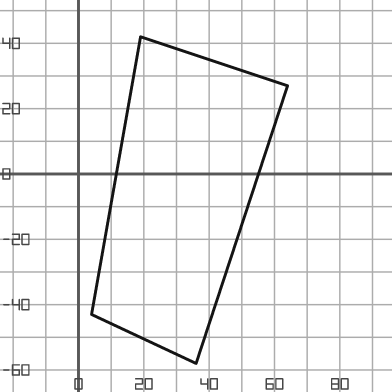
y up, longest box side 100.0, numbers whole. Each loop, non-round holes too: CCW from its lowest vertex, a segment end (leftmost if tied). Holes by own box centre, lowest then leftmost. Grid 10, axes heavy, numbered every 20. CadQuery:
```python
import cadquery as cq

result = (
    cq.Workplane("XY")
    .moveTo(36.0, -58.0)
    .lineTo(64.0, 27.0)
    .lineTo(19.0, 42.0)
    .lineTo(4.0, -43.0)
    .close()
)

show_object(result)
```